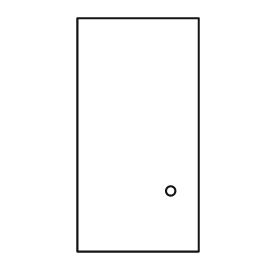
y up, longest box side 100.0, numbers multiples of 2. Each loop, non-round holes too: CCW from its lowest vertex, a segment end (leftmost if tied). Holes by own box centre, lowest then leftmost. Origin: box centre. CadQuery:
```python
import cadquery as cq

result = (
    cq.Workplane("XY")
    .moveTo(-26.0, -50.0)
    .lineTo(26.0, -50.0)
    .lineTo(26.0, 50.0)
    .lineTo(-26.0, 50.0)
    .close()
    .moveTo(14.0, -24.0)
    .circle(2.0)
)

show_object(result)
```